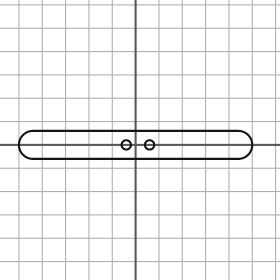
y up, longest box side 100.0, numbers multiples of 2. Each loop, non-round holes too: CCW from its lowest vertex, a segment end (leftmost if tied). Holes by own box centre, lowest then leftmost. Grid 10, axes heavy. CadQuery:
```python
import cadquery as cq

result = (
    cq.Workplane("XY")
    .moveTo(-44.0, -6.0)
    .lineTo(44.0, -6.0)
    .threePointArc((50.0, 0.0), (44.0, 6.0))
    .lineTo(-44.0, 6.0)
    .threePointArc((-50.0, 0.0), (-44.0, -6.0))
    .close()
    .moveTo(-4.0, 0.0)
    .circle(2.0)
    .moveTo(6.0, 0.0)
    .circle(2.0)
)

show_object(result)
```